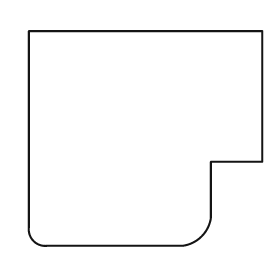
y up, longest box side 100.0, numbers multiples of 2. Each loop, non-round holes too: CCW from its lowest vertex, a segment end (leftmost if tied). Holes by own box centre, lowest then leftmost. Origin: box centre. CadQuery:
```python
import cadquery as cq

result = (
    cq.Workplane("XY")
    .moveTo(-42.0, -46.0)
    .lineTo(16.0, -46.0)
    .threePointArc((24.0, -42.0), (28.0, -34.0))
    .lineTo(28.0, -10.0)
    .lineTo(50.0, -10.0)
    .lineTo(50.0, 46.0)
    .lineTo(-50.0, 46.0)
    .lineTo(-50.0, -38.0)
    .threePointArc((-48.0, -44.0), (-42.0, -46.0))
    .close()
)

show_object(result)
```